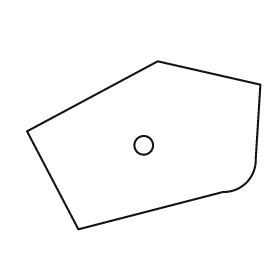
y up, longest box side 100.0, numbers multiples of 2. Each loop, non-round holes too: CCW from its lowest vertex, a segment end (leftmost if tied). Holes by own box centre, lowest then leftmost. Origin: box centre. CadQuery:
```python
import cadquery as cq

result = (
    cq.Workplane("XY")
    .moveTo(-28.0, -36.0)
    .lineTo(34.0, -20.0)
    .threePointArc((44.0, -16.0), (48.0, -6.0))
    .lineTo(50.0, 26.0)
    .lineTo(6.0, 36.0)
    .lineTo(-50.0, 6.0)
    .close()
    .moveTo(0.0, 0.0)
    .circle(4.0)
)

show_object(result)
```